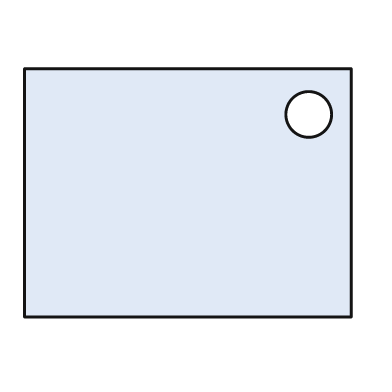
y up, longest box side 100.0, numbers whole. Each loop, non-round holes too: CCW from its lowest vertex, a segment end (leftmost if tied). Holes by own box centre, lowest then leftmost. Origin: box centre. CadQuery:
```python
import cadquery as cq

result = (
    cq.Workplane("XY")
    .moveTo(-50.0, -38.0)
    .lineTo(50.0, -38.0)
    .lineTo(50.0, 38.0)
    .lineTo(-50.0, 38.0)
    .close()
    .moveTo(37.0, 24.0)
    .circle(7.0)
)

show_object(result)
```